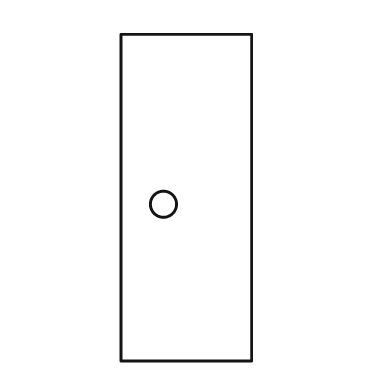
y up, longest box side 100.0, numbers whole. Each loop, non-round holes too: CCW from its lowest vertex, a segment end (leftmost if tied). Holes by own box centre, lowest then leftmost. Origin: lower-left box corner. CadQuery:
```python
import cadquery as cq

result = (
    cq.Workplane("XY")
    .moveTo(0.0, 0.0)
    .lineTo(40.0, 0.0)
    .lineTo(40.0, 100.0)
    .lineTo(0.0, 100.0)
    .close()
    .moveTo(13.0, 48.0)
    .circle(4.0)
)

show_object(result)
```